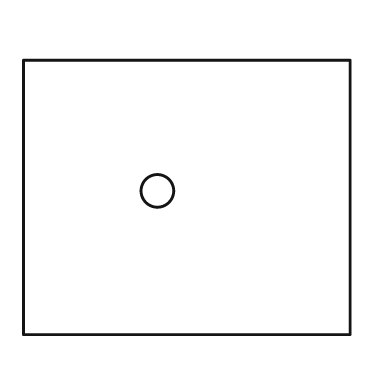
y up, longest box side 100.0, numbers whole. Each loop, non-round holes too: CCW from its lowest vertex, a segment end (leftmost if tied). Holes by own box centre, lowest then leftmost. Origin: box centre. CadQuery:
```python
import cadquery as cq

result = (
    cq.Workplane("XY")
    .moveTo(-50.0, -42.0)
    .lineTo(50.0, -42.0)
    .lineTo(50.0, 42.0)
    .lineTo(-50.0, 42.0)
    .close()
    .moveTo(-9.0, 2.0)
    .circle(5.0)
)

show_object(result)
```